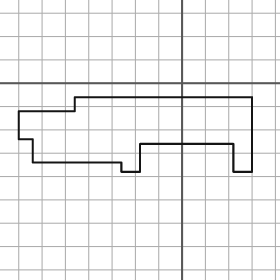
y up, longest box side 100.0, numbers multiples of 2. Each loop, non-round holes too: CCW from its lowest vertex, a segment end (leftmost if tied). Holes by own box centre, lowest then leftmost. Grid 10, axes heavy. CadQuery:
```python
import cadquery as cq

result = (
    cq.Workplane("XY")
    .moveTo(-26.0, -38.0)
    .lineTo(-18.0, -38.0)
    .lineTo(-18.0, -26.0)
    .lineTo(22.0, -26.0)
    .lineTo(22.0, -38.0)
    .lineTo(30.0, -38.0)
    .lineTo(30.0, -6.0)
    .lineTo(-46.0, -6.0)
    .lineTo(-46.0, -12.0)
    .lineTo(-70.0, -12.0)
    .lineTo(-70.0, -24.0)
    .lineTo(-64.0, -24.0)
    .lineTo(-64.0, -34.0)
    .lineTo(-26.0, -34.0)
    .close()
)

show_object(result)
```